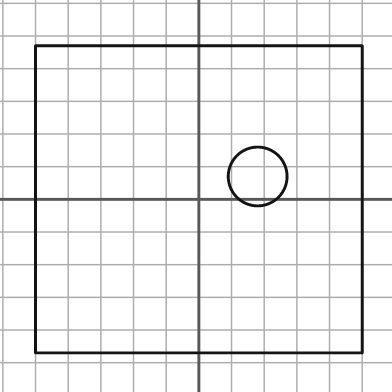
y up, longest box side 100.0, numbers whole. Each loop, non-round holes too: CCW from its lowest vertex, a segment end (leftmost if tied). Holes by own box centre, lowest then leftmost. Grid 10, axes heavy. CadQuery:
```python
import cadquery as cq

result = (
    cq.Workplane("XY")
    .moveTo(-50.0, -47.0)
    .lineTo(50.0, -47.0)
    .lineTo(50.0, 47.0)
    .lineTo(-50.0, 47.0)
    .close()
    .moveTo(18.0, 7.0)
    .circle(9.0)
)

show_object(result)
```